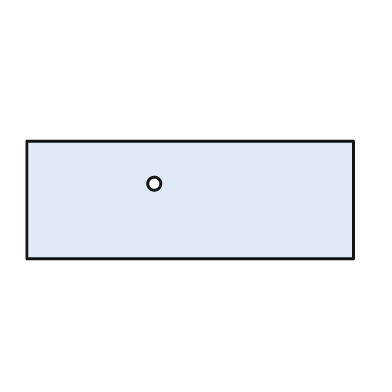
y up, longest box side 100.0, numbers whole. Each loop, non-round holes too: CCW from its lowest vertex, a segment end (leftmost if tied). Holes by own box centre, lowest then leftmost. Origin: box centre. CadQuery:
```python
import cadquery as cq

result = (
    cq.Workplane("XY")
    .moveTo(-50.0, -18.0)
    .lineTo(50.0, -18.0)
    .lineTo(50.0, 18.0)
    .lineTo(-50.0, 18.0)
    .close()
    .moveTo(-11.0, 5.0)
    .circle(2.0)
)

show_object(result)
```